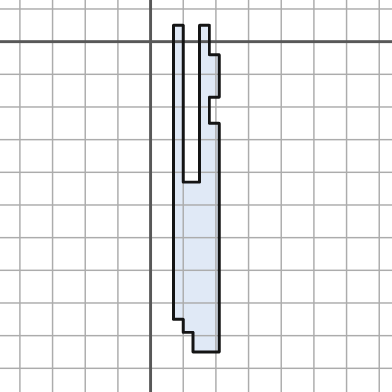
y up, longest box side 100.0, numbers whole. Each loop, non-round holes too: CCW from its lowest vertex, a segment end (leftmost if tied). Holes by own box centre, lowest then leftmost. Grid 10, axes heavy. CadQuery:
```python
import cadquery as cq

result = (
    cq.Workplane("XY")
    .moveTo(13.0, -95.0)
    .lineTo(21.0, -95.0)
    .lineTo(21.0, -25.0)
    .lineTo(18.0, -25.0)
    .lineTo(18.0, -17.0)
    .lineTo(21.0, -17.0)
    .lineTo(21.0, -4.0)
    .lineTo(18.0, -4.0)
    .lineTo(18.0, 5.0)
    .lineTo(15.0, 5.0)
    .lineTo(15.0, -43.0)
    .lineTo(10.0, -43.0)
    .lineTo(10.0, 5.0)
    .lineTo(7.0, 5.0)
    .lineTo(7.0, -85.0)
    .lineTo(10.0, -85.0)
    .lineTo(10.0, -89.0)
    .lineTo(13.0, -89.0)
    .close()
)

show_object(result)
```